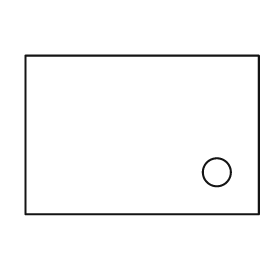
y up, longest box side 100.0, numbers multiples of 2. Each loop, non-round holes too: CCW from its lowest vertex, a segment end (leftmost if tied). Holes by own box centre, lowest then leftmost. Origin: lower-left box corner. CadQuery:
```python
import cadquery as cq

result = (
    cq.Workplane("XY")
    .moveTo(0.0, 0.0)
    .lineTo(100.0, 0.0)
    .lineTo(100.0, 68.0)
    .lineTo(0.0, 68.0)
    .close()
    .moveTo(82.0, 18.0)
    .circle(6.0)
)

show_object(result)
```